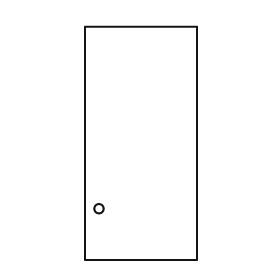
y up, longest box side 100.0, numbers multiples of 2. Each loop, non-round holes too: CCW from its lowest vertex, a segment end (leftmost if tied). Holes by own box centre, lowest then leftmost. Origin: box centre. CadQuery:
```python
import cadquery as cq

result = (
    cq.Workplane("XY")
    .moveTo(-24.0, -50.0)
    .lineTo(24.0, -50.0)
    .lineTo(24.0, 50.0)
    .lineTo(-24.0, 50.0)
    .close()
    .moveTo(-18.0, -28.0)
    .circle(2.0)
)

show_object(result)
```